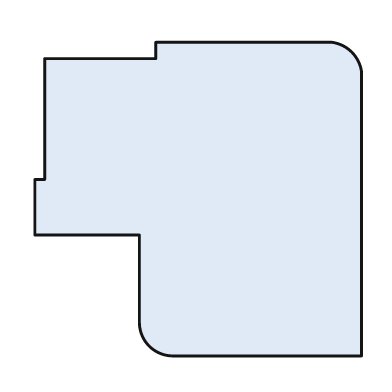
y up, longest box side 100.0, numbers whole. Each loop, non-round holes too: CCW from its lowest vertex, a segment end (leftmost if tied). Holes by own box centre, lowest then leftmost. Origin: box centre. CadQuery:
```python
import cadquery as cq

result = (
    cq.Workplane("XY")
    .moveTo(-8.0, -48.0)
    .lineTo(50.0, -48.0)
    .lineTo(50.0, 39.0)
    .threePointArc((47.0, 45.0), (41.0, 48.0))
    .lineTo(-13.0, 48.0)
    .lineTo(-13.0, 43.0)
    .lineTo(-47.0, 43.0)
    .lineTo(-47.0, 6.0)
    .lineTo(-50.0, 6.0)
    .lineTo(-50.0, -11.0)
    .lineTo(-18.0, -11.0)
    .lineTo(-18.0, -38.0)
    .threePointArc((-15.0, -45.0), (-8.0, -48.0))
    .close()
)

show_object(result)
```